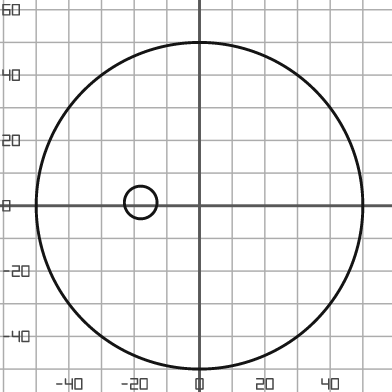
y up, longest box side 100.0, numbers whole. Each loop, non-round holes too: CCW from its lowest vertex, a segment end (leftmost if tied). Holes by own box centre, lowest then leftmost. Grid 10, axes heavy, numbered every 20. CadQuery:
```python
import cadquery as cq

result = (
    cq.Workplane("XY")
    .moveTo(0.0, 0.0)
    .circle(50.0)
    .moveTo(-18.0, 1.0)
    .circle(5.0)
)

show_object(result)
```